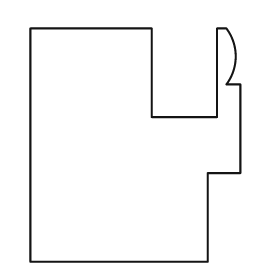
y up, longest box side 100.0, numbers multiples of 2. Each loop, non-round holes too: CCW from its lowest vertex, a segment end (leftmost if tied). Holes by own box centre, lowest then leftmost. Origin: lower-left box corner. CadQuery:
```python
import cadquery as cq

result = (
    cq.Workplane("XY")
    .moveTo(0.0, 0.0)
    .lineTo(76.0, 0.0)
    .lineTo(76.0, 38.0)
    .lineTo(90.0, 38.0)
    .lineTo(90.0, 76.0)
    .lineTo(84.0, 76.0)
    .threePointArc((88.0, 88.0), (84.0, 100.0))
    .lineTo(80.0, 100.0)
    .lineTo(80.0, 62.0)
    .lineTo(52.0, 62.0)
    .lineTo(52.0, 100.0)
    .lineTo(0.0, 100.0)
    .close()
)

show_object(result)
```